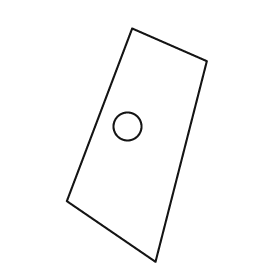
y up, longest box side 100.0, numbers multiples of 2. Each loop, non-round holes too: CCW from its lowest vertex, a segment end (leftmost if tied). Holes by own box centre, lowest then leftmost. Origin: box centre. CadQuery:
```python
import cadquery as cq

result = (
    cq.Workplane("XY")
    .moveTo(8.0, -50.0)
    .lineTo(30.0, 36.0)
    .lineTo(-2.0, 50.0)
    .lineTo(-30.0, -24.0)
    .close()
    .moveTo(-4.0, 8.0)
    .circle(6.0)
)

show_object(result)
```